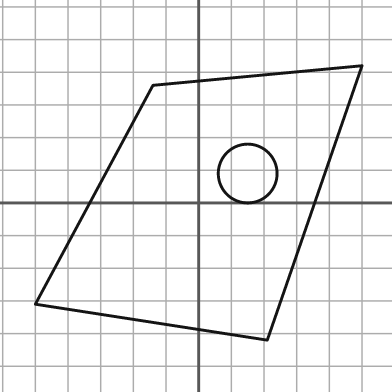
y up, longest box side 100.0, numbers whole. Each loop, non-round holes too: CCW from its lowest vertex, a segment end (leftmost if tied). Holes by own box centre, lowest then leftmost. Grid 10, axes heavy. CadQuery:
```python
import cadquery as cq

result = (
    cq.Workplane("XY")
    .moveTo(21.0, -42.0)
    .lineTo(50.0, 42.0)
    .lineTo(-14.0, 36.0)
    .lineTo(-50.0, -31.0)
    .close()
    .moveTo(15.0, 9.0)
    .circle(9.0)
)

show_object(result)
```